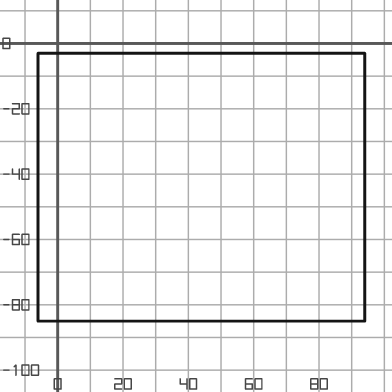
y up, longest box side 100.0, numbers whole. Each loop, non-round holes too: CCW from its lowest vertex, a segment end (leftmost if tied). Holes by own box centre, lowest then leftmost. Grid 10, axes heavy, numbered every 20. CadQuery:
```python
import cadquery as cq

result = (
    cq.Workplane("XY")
    .moveTo(-6.0, -85.0)
    .lineTo(94.0, -85.0)
    .lineTo(94.0, -3.0)
    .lineTo(-6.0, -3.0)
    .close()
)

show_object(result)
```